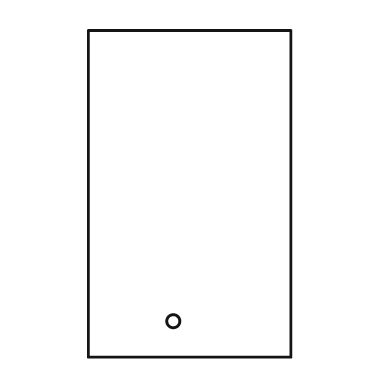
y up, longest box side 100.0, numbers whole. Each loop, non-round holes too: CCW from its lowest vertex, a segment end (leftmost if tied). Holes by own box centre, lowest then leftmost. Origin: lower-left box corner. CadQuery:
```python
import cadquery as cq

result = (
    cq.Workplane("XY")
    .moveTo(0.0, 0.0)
    .lineTo(62.0, 0.0)
    .lineTo(62.0, 100.0)
    .lineTo(0.0, 100.0)
    .close()
    .moveTo(26.0, 11.0)
    .circle(2.0)
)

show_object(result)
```